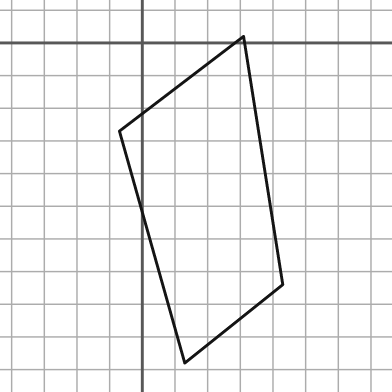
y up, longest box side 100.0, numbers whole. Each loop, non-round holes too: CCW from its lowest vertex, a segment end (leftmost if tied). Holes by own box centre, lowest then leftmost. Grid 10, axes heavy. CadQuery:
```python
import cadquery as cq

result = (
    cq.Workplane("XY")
    .moveTo(13.0, -98.0)
    .lineTo(43.0, -74.0)
    .lineTo(31.0, 2.0)
    .lineTo(-7.0, -27.0)
    .close()
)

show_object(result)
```